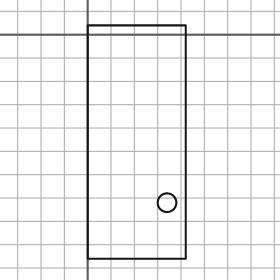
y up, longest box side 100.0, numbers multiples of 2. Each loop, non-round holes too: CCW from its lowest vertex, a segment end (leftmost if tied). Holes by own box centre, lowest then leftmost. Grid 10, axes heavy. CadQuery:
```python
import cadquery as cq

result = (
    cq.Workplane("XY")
    .moveTo(0.0, -96.0)
    .lineTo(42.0, -96.0)
    .lineTo(42.0, 4.0)
    .lineTo(0.0, 4.0)
    .close()
    .moveTo(34.0, -72.0)
    .circle(4.0)
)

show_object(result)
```